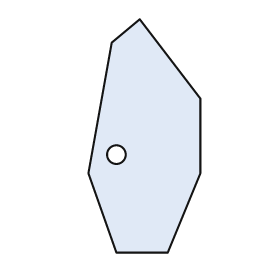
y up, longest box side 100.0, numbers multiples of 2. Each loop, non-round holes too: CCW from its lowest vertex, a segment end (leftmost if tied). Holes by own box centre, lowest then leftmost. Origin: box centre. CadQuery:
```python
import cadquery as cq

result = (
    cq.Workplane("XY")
    .moveTo(-12.0, -50.0)
    .lineTo(10.0, -50.0)
    .lineTo(24.0, -16.0)
    .lineTo(24.0, 16.0)
    .lineTo(-2.0, 50.0)
    .lineTo(-14.0, 40.0)
    .lineTo(-24.0, -16.0)
    .close()
    .moveTo(-12.0, -8.0)
    .circle(4.0)
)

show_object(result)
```